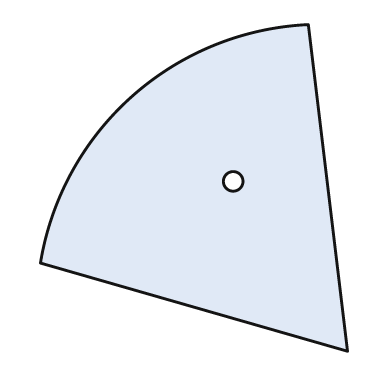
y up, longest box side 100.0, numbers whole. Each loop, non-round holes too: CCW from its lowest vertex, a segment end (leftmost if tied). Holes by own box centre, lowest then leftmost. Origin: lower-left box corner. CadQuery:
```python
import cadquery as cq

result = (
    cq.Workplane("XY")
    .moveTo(94.0, 0.0)
    .lineTo(82.0, 100.0)
    .threePointArc((28.0, 78.0), (0.0, 27.0))
    .close()
    .moveTo(59.0, 52.0)
    .circle(3.0)
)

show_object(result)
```